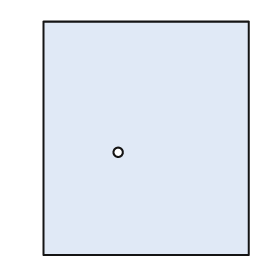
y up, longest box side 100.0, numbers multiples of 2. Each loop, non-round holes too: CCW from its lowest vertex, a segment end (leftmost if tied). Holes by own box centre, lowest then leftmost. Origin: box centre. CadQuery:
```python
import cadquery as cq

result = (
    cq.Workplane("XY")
    .moveTo(-44.0, -50.0)
    .lineTo(44.0, -50.0)
    .lineTo(44.0, 50.0)
    .lineTo(-44.0, 50.0)
    .close()
    .moveTo(-12.0, -6.0)
    .circle(2.0)
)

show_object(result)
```